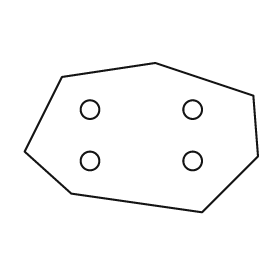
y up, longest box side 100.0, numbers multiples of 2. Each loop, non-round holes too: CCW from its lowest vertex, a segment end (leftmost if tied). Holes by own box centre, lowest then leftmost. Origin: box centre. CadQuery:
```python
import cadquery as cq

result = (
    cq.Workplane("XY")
    .moveTo(26.0, -32.0)
    .lineTo(50.0, -8.0)
    .lineTo(48.0, 18.0)
    .lineTo(6.0, 32.0)
    .lineTo(-34.0, 26.0)
    .lineTo(-50.0, -6.0)
    .lineTo(-30.0, -24.0)
    .close()
    .moveTo(-22.0, -10.0)
    .circle(4.0)
    .moveTo(22.0, -10.0)
    .circle(4.0)
    .moveTo(-22.0, 12.0)
    .circle(4.0)
    .moveTo(22.0, 12.0)
    .circle(4.0)
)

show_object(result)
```